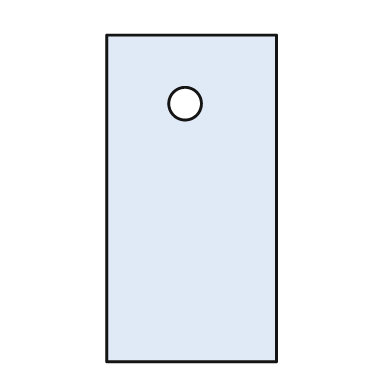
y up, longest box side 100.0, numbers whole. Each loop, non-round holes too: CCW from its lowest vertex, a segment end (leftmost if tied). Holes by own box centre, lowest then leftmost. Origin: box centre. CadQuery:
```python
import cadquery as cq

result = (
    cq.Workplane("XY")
    .moveTo(-26.0, -50.0)
    .lineTo(26.0, -50.0)
    .lineTo(26.0, 50.0)
    .lineTo(-26.0, 50.0)
    .close()
    .moveTo(-2.0, 29.0)
    .circle(5.0)
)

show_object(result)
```